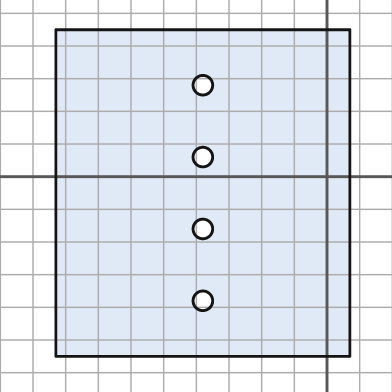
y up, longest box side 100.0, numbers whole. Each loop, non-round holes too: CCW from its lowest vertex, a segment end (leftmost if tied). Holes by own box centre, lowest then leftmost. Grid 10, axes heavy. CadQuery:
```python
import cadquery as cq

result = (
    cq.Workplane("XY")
    .moveTo(-83.0, -55.0)
    .lineTo(7.0, -55.0)
    .lineTo(7.0, 45.0)
    .lineTo(-83.0, 45.0)
    .close()
    .moveTo(-38.0, -38.0)
    .circle(3.0)
    .moveTo(-38.0, -16.0)
    .circle(3.0)
    .moveTo(-38.0, 6.0)
    .circle(3.0)
    .moveTo(-38.0, 28.0)
    .circle(3.0)
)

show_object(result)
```